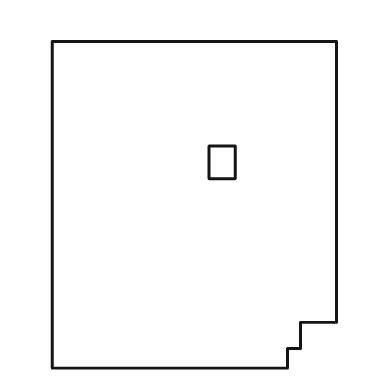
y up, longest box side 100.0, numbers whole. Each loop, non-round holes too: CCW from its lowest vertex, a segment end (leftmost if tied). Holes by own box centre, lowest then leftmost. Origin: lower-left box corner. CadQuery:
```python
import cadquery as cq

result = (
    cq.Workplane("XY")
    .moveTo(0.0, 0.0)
    .lineTo(72.0, 0.0)
    .lineTo(72.0, 6.0)
    .lineTo(76.0, 6.0)
    .lineTo(76.0, 14.0)
    .lineTo(87.0, 14.0)
    .lineTo(87.0, 100.0)
    .lineTo(0.0, 100.0)
    .close()
    .moveTo(48.0, 58.0)
    .lineTo(56.0, 58.0)
    .lineTo(56.0, 68.0)
    .lineTo(48.0, 68.0)
    .close()
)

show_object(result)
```